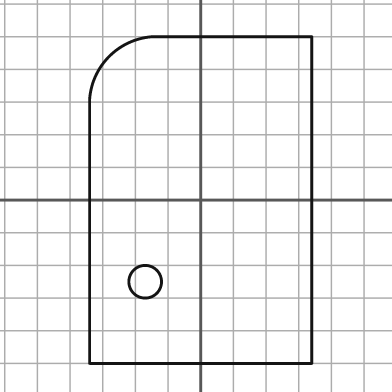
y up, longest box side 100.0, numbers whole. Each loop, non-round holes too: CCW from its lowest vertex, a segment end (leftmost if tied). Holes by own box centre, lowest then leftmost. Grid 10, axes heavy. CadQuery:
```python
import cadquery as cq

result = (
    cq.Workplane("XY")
    .moveTo(-34.0, -50.0)
    .lineTo(34.0, -50.0)
    .lineTo(34.0, 50.0)
    .lineTo(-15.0, 50.0)
    .threePointArc((-28.0, 44.0), (-34.0, 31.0))
    .close()
    .moveTo(-17.0, -25.0)
    .circle(5.0)
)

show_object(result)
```